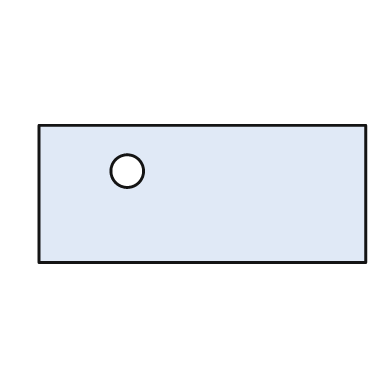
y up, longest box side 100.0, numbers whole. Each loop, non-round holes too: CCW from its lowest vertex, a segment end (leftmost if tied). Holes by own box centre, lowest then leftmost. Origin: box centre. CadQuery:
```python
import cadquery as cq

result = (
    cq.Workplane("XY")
    .moveTo(-50.0, -21.0)
    .lineTo(50.0, -21.0)
    .lineTo(50.0, 21.0)
    .lineTo(-50.0, 21.0)
    .close()
    .moveTo(-23.0, 7.0)
    .circle(5.0)
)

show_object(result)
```